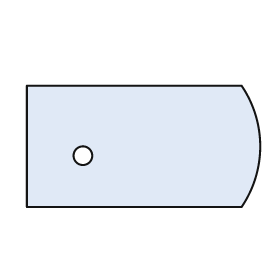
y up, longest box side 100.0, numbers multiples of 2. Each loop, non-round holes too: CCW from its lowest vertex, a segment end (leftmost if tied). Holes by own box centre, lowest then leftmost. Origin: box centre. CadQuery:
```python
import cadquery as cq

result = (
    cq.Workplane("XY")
    .moveTo(-50.0, -26.0)
    .lineTo(42.0, -26.0)
    .threePointArc((50.0, 0.0), (42.0, 26.0))
    .lineTo(-50.0, 26.0)
    .close()
    .moveTo(-26.0, -4.0)
    .circle(4.0)
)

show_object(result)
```